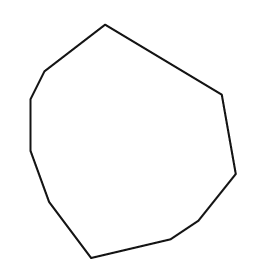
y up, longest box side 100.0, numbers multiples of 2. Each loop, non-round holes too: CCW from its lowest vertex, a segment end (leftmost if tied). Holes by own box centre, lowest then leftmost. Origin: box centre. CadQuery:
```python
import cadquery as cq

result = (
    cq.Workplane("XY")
    .moveTo(-18.0, -50.0)
    .lineTo(16.0, -42.0)
    .lineTo(28.0, -34.0)
    .lineTo(44.0, -14.0)
    .lineTo(38.0, 20.0)
    .lineTo(-12.0, 50.0)
    .lineTo(-38.0, 30.0)
    .lineTo(-44.0, 18.0)
    .lineTo(-44.0, -4.0)
    .lineTo(-36.0, -26.0)
    .close()
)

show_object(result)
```